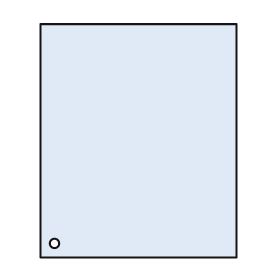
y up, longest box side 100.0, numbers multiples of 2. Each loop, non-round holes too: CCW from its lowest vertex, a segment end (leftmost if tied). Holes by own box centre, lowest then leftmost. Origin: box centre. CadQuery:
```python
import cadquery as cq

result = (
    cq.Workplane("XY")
    .moveTo(-42.0, -50.0)
    .lineTo(42.0, -50.0)
    .lineTo(42.0, 50.0)
    .lineTo(-42.0, 50.0)
    .close()
    .moveTo(-36.0, -44.0)
    .circle(2.0)
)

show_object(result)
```